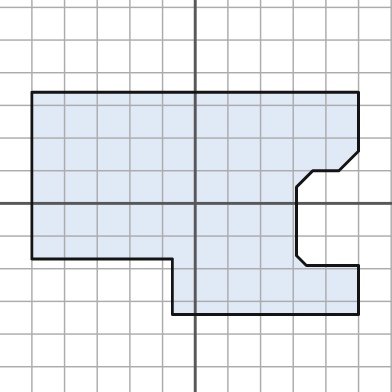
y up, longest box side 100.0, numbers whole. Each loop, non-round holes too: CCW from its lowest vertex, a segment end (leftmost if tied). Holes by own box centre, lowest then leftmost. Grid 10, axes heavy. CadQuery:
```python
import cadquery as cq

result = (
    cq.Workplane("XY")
    .moveTo(-7.0, -34.0)
    .lineTo(50.0, -34.0)
    .lineTo(50.0, -19.0)
    .lineTo(34.0, -19.0)
    .lineTo(31.0, -16.0)
    .lineTo(31.0, 5.0)
    .lineTo(36.0, 10.0)
    .lineTo(44.0, 10.0)
    .lineTo(50.0, 16.0)
    .lineTo(50.0, 34.0)
    .lineTo(-50.0, 34.0)
    .lineTo(-50.0, -17.0)
    .lineTo(-7.0, -17.0)
    .close()
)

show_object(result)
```